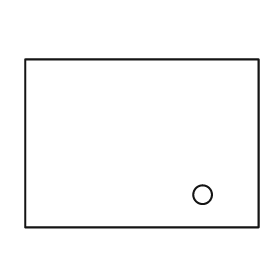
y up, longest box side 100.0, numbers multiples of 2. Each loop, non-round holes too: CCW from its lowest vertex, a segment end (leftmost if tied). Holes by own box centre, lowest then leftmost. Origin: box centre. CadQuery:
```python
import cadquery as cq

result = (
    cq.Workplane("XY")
    .moveTo(-50.0, -36.0)
    .lineTo(50.0, -36.0)
    .lineTo(50.0, 36.0)
    .lineTo(-50.0, 36.0)
    .close()
    .moveTo(26.0, -22.0)
    .circle(4.0)
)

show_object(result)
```